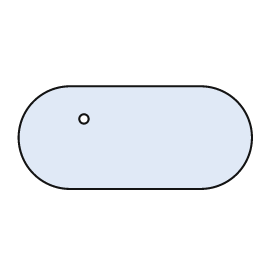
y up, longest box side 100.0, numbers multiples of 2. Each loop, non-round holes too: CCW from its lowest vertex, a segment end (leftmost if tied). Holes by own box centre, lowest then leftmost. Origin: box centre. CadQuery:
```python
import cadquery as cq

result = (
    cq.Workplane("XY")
    .moveTo(-28.0, -22.0)
    .lineTo(28.0, -22.0)
    .threePointArc((50.0, 0.0), (28.0, 22.0))
    .lineTo(-28.0, 22.0)
    .threePointArc((-50.0, 0.0), (-28.0, -22.0))
    .close()
    .moveTo(-22.0, 8.0)
    .circle(2.0)
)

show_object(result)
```